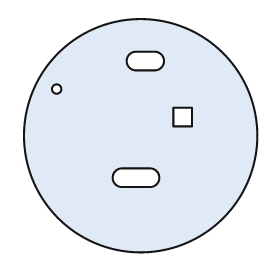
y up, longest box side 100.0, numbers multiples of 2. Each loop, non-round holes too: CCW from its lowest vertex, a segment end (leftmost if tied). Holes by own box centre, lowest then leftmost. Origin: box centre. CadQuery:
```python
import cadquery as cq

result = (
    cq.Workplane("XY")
    .moveTo(0.0, 0.0)
    .circle(50.0)
    .moveTo(-8.0, -22.0)
    .lineTo(4.0, -22.0)
    .threePointArc((8.0, -18.0), (4.0, -14.0))
    .lineTo(-8.0, -14.0)
    .threePointArc((-12.0, -18.0), (-8.0, -22.0))
    .close()
    .moveTo(14.0, 4.0)
    .lineTo(22.0, 4.0)
    .lineTo(22.0, 12.0)
    .lineTo(14.0, 12.0)
    .close()
    .moveTo(-36.0, 20.0)
    .circle(2.0)
    .moveTo(-2.0, 28.0)
    .lineTo(6.0, 28.0)
    .threePointArc((10.0, 32.0), (6.0, 36.0))
    .lineTo(-2.0, 36.0)
    .threePointArc((-6.0, 32.0), (-2.0, 28.0))
    .close()
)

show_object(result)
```